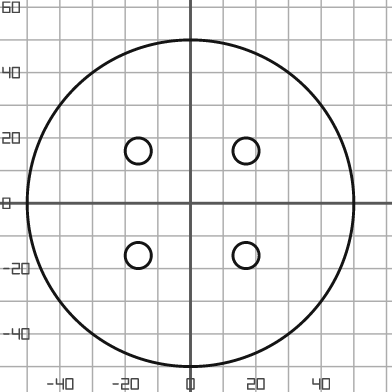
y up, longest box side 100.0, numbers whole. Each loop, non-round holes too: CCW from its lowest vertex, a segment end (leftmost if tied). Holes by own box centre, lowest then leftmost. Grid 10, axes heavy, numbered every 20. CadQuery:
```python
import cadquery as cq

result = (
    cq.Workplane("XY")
    .moveTo(0.0, 0.0)
    .circle(50.0)
    .moveTo(-16.0, -16.0)
    .circle(4.0)
    .moveTo(17.0, -16.0)
    .circle(4.0)
    .moveTo(-16.0, 16.0)
    .circle(4.0)
    .moveTo(17.0, 16.0)
    .circle(4.0)
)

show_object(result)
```